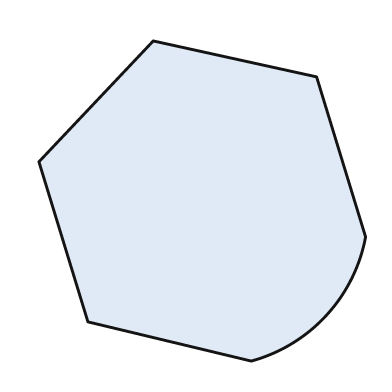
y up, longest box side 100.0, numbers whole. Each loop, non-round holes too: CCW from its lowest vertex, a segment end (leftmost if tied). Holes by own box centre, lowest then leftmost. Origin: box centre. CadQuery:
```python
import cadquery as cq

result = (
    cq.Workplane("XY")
    .moveTo(15.0, -49.0)
    .threePointArc((38.0, -35.0), (50.0, -11.0))
    .lineTo(35.0, 38.0)
    .lineTo(-15.0, 49.0)
    .lineTo(-50.0, 12.0)
    .lineTo(-35.0, -37.0)
    .close()
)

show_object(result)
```